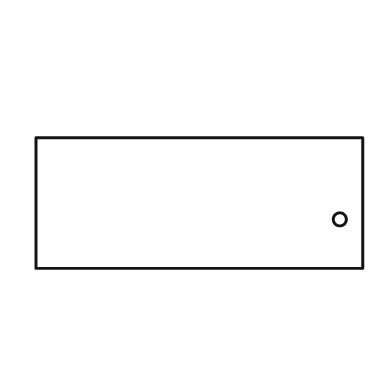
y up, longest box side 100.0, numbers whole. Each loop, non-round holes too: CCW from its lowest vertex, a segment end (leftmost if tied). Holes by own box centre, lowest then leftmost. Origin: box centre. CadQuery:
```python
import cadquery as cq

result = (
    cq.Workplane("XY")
    .moveTo(-50.0, -20.0)
    .lineTo(50.0, -20.0)
    .lineTo(50.0, 20.0)
    .lineTo(-50.0, 20.0)
    .close()
    .moveTo(43.0, -5.0)
    .circle(2.0)
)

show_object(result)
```